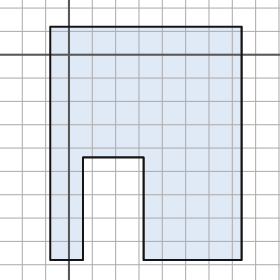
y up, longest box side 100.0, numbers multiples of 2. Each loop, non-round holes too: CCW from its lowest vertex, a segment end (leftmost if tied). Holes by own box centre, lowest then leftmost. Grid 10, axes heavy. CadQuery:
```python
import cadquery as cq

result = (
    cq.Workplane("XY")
    .moveTo(-8.0, -88.0)
    .lineTo(6.0, -88.0)
    .lineTo(6.0, -44.0)
    .lineTo(32.0, -44.0)
    .lineTo(32.0, -88.0)
    .lineTo(74.0, -88.0)
    .lineTo(74.0, 12.0)
    .lineTo(-8.0, 12.0)
    .close()
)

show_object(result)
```